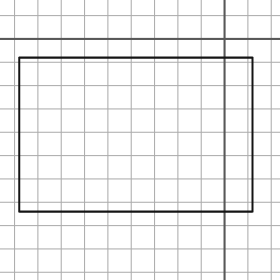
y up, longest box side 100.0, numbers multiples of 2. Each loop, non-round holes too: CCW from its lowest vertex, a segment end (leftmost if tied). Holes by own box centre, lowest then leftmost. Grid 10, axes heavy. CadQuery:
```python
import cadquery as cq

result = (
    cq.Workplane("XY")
    .moveTo(-88.0, -74.0)
    .lineTo(12.0, -74.0)
    .lineTo(12.0, -8.0)
    .lineTo(-88.0, -8.0)
    .close()
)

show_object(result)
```